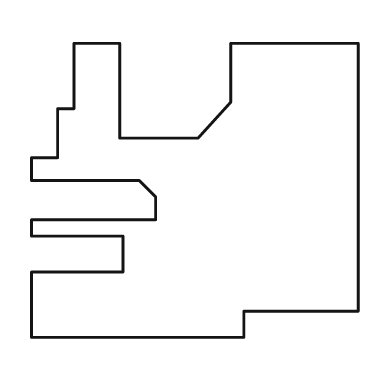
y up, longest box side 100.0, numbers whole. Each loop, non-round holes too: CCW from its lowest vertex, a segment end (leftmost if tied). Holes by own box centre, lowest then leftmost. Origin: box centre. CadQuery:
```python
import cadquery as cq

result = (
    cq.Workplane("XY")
    .moveTo(-50.0, -45.0)
    .lineTo(15.0, -45.0)
    .lineTo(15.0, -37.0)
    .lineTo(50.0, -37.0)
    .lineTo(50.0, 45.0)
    .lineTo(11.0, 45.0)
    .lineTo(11.0, 27.0)
    .lineTo(1.0, 16.0)
    .lineTo(-23.0, 16.0)
    .lineTo(-23.0, 45.0)
    .lineTo(-37.0, 45.0)
    .lineTo(-37.0, 25.0)
    .lineTo(-42.0, 25.0)
    .lineTo(-42.0, 10.0)
    .lineTo(-50.0, 10.0)
    .lineTo(-50.0, 3.0)
    .lineTo(-17.0, 3.0)
    .lineTo(-12.0, -2.0)
    .lineTo(-12.0, -9.0)
    .lineTo(-50.0, -9.0)
    .lineTo(-50.0, -14.0)
    .lineTo(-22.0, -14.0)
    .lineTo(-22.0, -25.0)
    .lineTo(-50.0, -25.0)
    .close()
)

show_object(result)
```